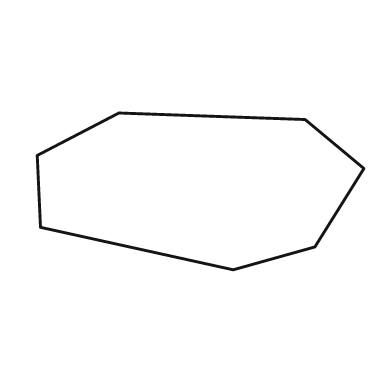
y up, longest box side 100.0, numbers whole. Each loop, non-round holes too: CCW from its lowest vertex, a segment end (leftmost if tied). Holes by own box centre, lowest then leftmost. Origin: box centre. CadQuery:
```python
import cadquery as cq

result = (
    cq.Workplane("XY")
    .moveTo(10.0, -24.0)
    .lineTo(35.0, -17.0)
    .lineTo(50.0, 7.0)
    .lineTo(32.0, 22.0)
    .lineTo(-25.0, 24.0)
    .lineTo(-50.0, 11.0)
    .lineTo(-49.0, -11.0)
    .close()
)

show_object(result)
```